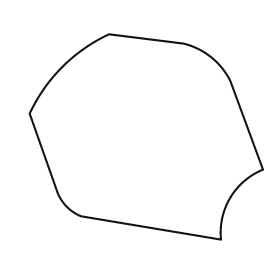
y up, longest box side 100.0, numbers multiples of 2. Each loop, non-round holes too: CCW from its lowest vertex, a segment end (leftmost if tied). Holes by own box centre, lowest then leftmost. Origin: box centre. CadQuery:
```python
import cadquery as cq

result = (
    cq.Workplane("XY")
    .moveTo(32.0, -44.0)
    .threePointArc((36.0, -26.0), (50.0, -14.0))
    .lineTo(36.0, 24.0)
    .threePointArc((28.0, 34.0), (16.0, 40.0))
    .lineTo(-16.0, 44.0)
    .threePointArc((-36.0, 30.0), (-50.0, 10.0))
    .lineTo(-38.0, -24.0)
    .threePointArc((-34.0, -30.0), (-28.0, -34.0))
    .close()
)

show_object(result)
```